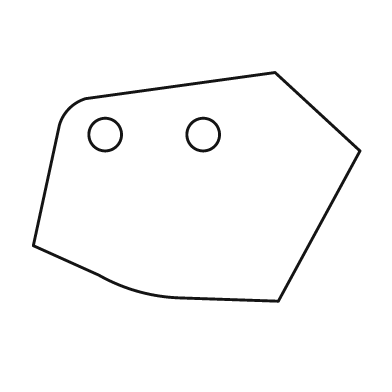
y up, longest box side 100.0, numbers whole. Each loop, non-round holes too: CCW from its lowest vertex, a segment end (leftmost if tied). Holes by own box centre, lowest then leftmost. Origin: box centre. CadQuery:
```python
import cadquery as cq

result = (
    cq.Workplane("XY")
    .moveTo(25.0, -35.0)
    .lineTo(50.0, 11.0)
    .lineTo(24.0, 35.0)
    .lineTo(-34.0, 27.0)
    .threePointArc((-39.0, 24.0), (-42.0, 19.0))
    .lineTo(-50.0, -18.0)
    .lineTo(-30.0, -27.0)
    .threePointArc((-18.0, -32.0), (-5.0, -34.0))
    .close()
    .moveTo(-28.0, 16.0)
    .circle(5.0)
    .moveTo(2.0, 16.0)
    .circle(5.0)
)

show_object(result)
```